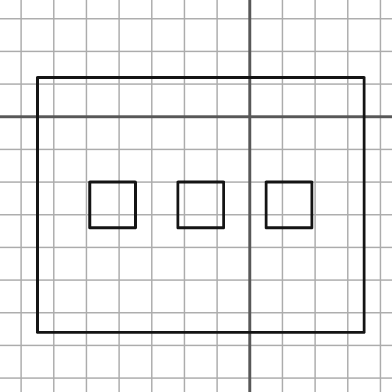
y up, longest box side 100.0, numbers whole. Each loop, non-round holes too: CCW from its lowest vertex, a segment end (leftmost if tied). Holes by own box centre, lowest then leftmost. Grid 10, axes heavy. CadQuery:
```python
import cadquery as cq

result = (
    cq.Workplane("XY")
    .moveTo(-65.0, -66.0)
    .lineTo(35.0, -66.0)
    .lineTo(35.0, 12.0)
    .lineTo(-65.0, 12.0)
    .close()
    .moveTo(-49.0, -34.0)
    .lineTo(-35.0, -34.0)
    .lineTo(-35.0, -20.0)
    .lineTo(-49.0, -20.0)
    .close()
    .moveTo(-22.0, -34.0)
    .lineTo(-8.0, -34.0)
    .lineTo(-8.0, -20.0)
    .lineTo(-22.0, -20.0)
    .close()
    .moveTo(5.0, -34.0)
    .lineTo(19.0, -34.0)
    .lineTo(19.0, -20.0)
    .lineTo(5.0, -20.0)
    .close()
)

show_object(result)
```